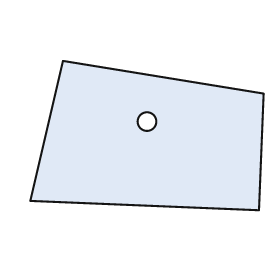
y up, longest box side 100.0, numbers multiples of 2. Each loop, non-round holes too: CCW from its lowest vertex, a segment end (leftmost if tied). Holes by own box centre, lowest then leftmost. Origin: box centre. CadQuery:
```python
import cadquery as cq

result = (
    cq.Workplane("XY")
    .moveTo(48.0, -32.0)
    .lineTo(50.0, 18.0)
    .lineTo(-36.0, 32.0)
    .lineTo(-50.0, -28.0)
    .close()
    .moveTo(0.0, 6.0)
    .circle(4.0)
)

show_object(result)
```